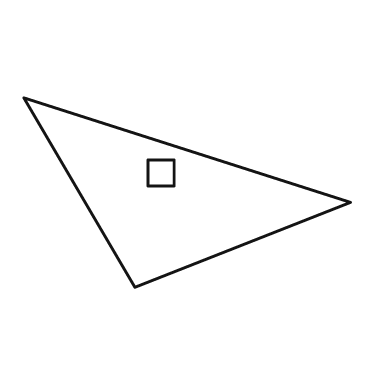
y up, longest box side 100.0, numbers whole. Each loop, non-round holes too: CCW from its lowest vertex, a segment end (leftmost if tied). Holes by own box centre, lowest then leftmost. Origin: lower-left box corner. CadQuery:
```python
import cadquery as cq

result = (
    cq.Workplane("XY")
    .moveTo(34.0, 0.0)
    .lineTo(100.0, 26.0)
    .lineTo(0.0, 58.0)
    .close()
    .moveTo(38.0, 31.0)
    .lineTo(46.0, 31.0)
    .lineTo(46.0, 39.0)
    .lineTo(38.0, 39.0)
    .close()
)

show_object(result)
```